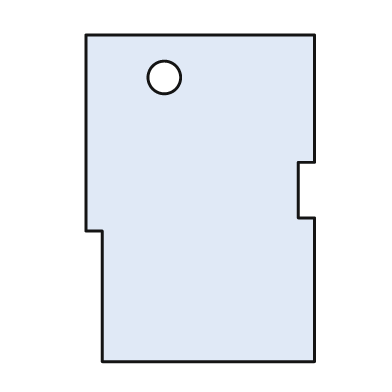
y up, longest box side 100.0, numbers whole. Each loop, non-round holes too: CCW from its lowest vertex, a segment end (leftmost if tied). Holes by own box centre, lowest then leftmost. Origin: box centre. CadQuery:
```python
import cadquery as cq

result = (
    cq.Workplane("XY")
    .moveTo(-30.0, -50.0)
    .lineTo(35.0, -50.0)
    .lineTo(35.0, -6.0)
    .lineTo(30.0, -6.0)
    .lineTo(30.0, 11.0)
    .lineTo(35.0, 11.0)
    .lineTo(35.0, 50.0)
    .lineTo(-35.0, 50.0)
    .lineTo(-35.0, -10.0)
    .lineTo(-30.0, -10.0)
    .close()
    .moveTo(-11.0, 37.0)
    .circle(5.0)
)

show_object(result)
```